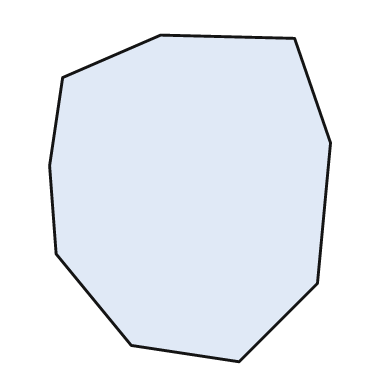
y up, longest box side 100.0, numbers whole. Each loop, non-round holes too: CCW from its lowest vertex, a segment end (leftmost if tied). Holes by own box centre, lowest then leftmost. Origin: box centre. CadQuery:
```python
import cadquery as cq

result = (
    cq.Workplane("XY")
    .moveTo(15.0, -50.0)
    .lineTo(39.0, -26.0)
    .lineTo(43.0, 17.0)
    .lineTo(32.0, 49.0)
    .lineTo(-9.0, 50.0)
    .lineTo(-39.0, 37.0)
    .lineTo(-43.0, 10.0)
    .lineTo(-41.0, -17.0)
    .lineTo(-18.0, -45.0)
    .close()
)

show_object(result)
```